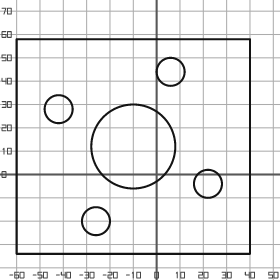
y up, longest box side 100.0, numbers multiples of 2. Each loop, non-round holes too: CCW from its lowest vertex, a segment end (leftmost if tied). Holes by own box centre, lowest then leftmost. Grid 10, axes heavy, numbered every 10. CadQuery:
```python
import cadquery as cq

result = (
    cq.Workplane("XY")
    .moveTo(-60.0, -34.0)
    .lineTo(40.0, -34.0)
    .lineTo(40.0, 58.0)
    .lineTo(-60.0, 58.0)
    .close()
    .moveTo(-26.0, -20.0)
    .circle(6.0)
    .moveTo(22.0, -4.0)
    .circle(6.0)
    .moveTo(-10.0, 12.0)
    .circle(18.0)
    .moveTo(-42.0, 28.0)
    .circle(6.0)
    .moveTo(6.0, 44.0)
    .circle(6.0)
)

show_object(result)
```